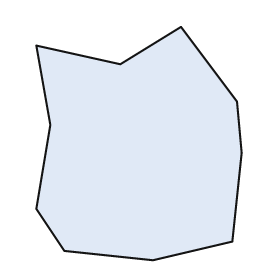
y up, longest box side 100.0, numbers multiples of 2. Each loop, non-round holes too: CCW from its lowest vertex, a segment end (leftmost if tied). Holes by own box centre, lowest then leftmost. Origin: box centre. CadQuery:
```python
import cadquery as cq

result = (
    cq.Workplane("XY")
    .moveTo(6.0, -50.0)
    .lineTo(40.0, -42.0)
    .lineTo(44.0, -4.0)
    .lineTo(42.0, 18.0)
    .lineTo(18.0, 50.0)
    .lineTo(-8.0, 34.0)
    .lineTo(-44.0, 42.0)
    .lineTo(-38.0, 8.0)
    .lineTo(-44.0, -28.0)
    .lineTo(-32.0, -46.0)
    .close()
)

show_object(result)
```